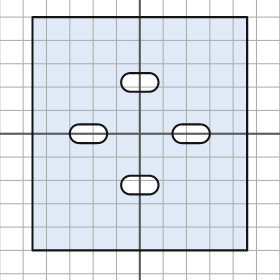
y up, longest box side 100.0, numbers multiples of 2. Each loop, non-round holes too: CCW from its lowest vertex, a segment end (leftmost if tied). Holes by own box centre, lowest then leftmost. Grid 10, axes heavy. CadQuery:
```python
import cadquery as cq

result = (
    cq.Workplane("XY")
    .moveTo(-46.0, -50.0)
    .lineTo(46.0, -50.0)
    .lineTo(46.0, 50.0)
    .lineTo(-46.0, 50.0)
    .close()
    .moveTo(-4.0, -26.0)
    .lineTo(4.0, -26.0)
    .threePointArc((8.0, -22.0), (4.0, -18.0))
    .lineTo(-4.0, -18.0)
    .threePointArc((-8.0, -22.0), (-4.0, -26.0))
    .close()
    .moveTo(-26.0, -4.0)
    .lineTo(-18.0, -4.0)
    .threePointArc((-14.0, 0.0), (-18.0, 4.0))
    .lineTo(-26.0, 4.0)
    .threePointArc((-30.0, 0.0), (-26.0, -4.0))
    .close()
    .moveTo(18.0, -4.0)
    .lineTo(26.0, -4.0)
    .threePointArc((30.0, 0.0), (26.0, 4.0))
    .lineTo(18.0, 4.0)
    .threePointArc((14.0, 0.0), (18.0, -4.0))
    .close()
    .moveTo(-4.0, 18.0)
    .lineTo(4.0, 18.0)
    .threePointArc((8.0, 22.0), (4.0, 26.0))
    .lineTo(-4.0, 26.0)
    .threePointArc((-8.0, 22.0), (-4.0, 18.0))
    .close()
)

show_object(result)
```